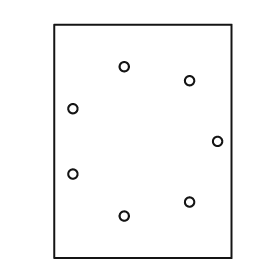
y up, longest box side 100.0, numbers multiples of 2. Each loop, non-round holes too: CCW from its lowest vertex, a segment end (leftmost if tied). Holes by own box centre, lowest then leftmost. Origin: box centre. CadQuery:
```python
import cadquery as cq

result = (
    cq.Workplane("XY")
    .moveTo(-38.0, -50.0)
    .lineTo(38.0, -50.0)
    .lineTo(38.0, 50.0)
    .lineTo(-38.0, 50.0)
    .close()
    .moveTo(-8.0, -32.0)
    .circle(2.0)
    .moveTo(20.0, -26.0)
    .circle(2.0)
    .moveTo(-30.0, -14.0)
    .circle(2.0)
    .moveTo(32.0, 0.0)
    .circle(2.0)
    .moveTo(-30.0, 14.0)
    .circle(2.0)
    .moveTo(20.0, 26.0)
    .circle(2.0)
    .moveTo(-8.0, 32.0)
    .circle(2.0)
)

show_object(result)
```